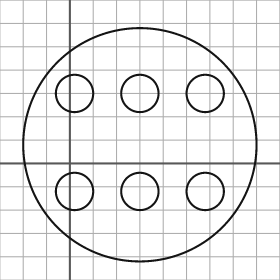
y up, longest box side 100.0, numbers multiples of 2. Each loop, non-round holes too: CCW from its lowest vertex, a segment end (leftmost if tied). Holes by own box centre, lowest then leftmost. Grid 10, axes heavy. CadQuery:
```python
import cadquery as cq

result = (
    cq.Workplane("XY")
    .moveTo(30.0, 8.0)
    .circle(50.0)
    .moveTo(2.0, -12.0)
    .circle(8.0)
    .moveTo(30.0, -12.0)
    .circle(8.0)
    .moveTo(58.0, -12.0)
    .circle(8.0)
    .moveTo(2.0, 30.0)
    .circle(8.0)
    .moveTo(30.0, 30.0)
    .circle(8.0)
    .moveTo(58.0, 30.0)
    .circle(8.0)
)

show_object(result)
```